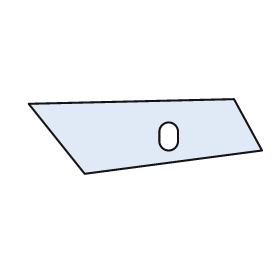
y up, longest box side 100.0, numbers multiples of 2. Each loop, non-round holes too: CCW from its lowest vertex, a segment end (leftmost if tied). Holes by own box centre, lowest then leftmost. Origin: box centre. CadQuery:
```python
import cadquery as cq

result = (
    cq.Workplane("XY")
    .moveTo(-26.0, -16.0)
    .lineTo(50.0, -6.0)
    .lineTo(38.0, 16.0)
    .lineTo(-50.0, 14.0)
    .close()
    .moveTo(6.0, -2.0)
    .threePointArc((10.0, -6.0), (14.0, -2.0))
    .lineTo(14.0, 2.0)
    .threePointArc((10.0, 6.0), (6.0, 2.0))
    .close()
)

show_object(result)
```